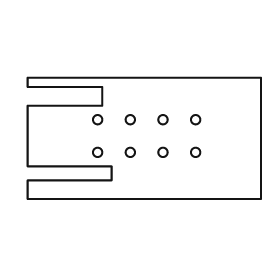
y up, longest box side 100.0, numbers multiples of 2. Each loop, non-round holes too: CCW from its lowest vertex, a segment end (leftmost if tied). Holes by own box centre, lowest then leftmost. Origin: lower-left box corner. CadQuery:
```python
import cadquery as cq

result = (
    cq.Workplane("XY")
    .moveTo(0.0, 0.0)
    .lineTo(100.0, 0.0)
    .lineTo(100.0, 52.0)
    .lineTo(0.0, 52.0)
    .lineTo(0.0, 48.0)
    .lineTo(32.0, 48.0)
    .lineTo(32.0, 40.0)
    .lineTo(0.0, 40.0)
    .lineTo(0.0, 14.0)
    .lineTo(36.0, 14.0)
    .lineTo(36.0, 8.0)
    .lineTo(0.0, 8.0)
    .close()
    .moveTo(30.0, 20.0)
    .circle(2.0)
    .moveTo(44.0, 20.0)
    .circle(2.0)
    .moveTo(58.0, 20.0)
    .circle(2.0)
    .moveTo(72.0, 20.0)
    .circle(2.0)
    .moveTo(30.0, 34.0)
    .circle(2.0)
    .moveTo(44.0, 34.0)
    .circle(2.0)
    .moveTo(58.0, 34.0)
    .circle(2.0)
    .moveTo(72.0, 34.0)
    .circle(2.0)
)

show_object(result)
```